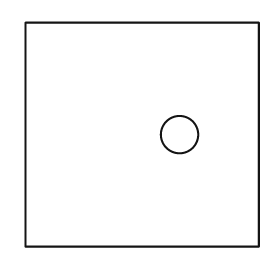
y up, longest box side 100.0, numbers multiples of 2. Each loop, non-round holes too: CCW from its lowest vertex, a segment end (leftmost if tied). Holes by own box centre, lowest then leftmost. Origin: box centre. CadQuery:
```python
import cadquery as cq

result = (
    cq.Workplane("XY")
    .moveTo(-50.0, -48.0)
    .lineTo(50.0, -48.0)
    .lineTo(50.0, 48.0)
    .lineTo(-50.0, 48.0)
    .close()
    .moveTo(16.0, 0.0)
    .circle(8.0)
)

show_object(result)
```